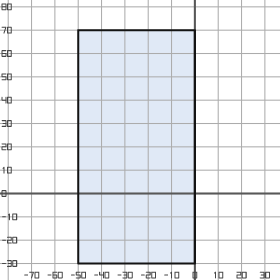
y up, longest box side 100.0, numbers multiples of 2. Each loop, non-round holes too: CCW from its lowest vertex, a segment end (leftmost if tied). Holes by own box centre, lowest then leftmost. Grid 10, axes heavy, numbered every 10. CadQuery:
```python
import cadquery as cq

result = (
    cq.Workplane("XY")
    .moveTo(-50.0, -30.0)
    .lineTo(0.0, -30.0)
    .lineTo(0.0, 70.0)
    .lineTo(-50.0, 70.0)
    .close()
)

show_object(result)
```